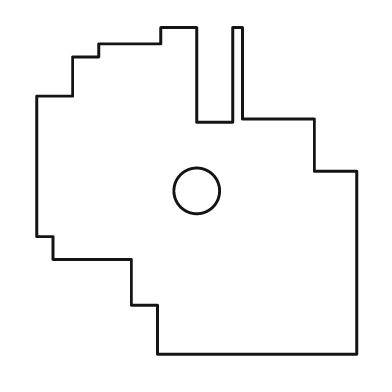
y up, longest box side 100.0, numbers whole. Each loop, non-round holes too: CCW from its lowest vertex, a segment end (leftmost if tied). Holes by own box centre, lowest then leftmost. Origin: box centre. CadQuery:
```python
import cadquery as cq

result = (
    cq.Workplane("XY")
    .moveTo(-12.0, -50.0)
    .lineTo(49.0, -50.0)
    .lineTo(49.0, 6.0)
    .lineTo(36.0, 6.0)
    .lineTo(36.0, 22.0)
    .lineTo(14.0, 22.0)
    .lineTo(14.0, 50.0)
    .lineTo(11.0, 50.0)
    .lineTo(11.0, 21.0)
    .lineTo(0.0, 21.0)
    .lineTo(0.0, 50.0)
    .lineTo(-11.0, 50.0)
    .lineTo(-11.0, 45.0)
    .lineTo(-30.0, 45.0)
    .lineTo(-30.0, 41.0)
    .lineTo(-38.0, 41.0)
    .lineTo(-38.0, 29.0)
    .lineTo(-49.0, 29.0)
    .lineTo(-49.0, -14.0)
    .lineTo(-44.0, -14.0)
    .lineTo(-44.0, -21.0)
    .lineTo(-20.0, -21.0)
    .lineTo(-20.0, -35.0)
    .lineTo(-12.0, -35.0)
    .close()
    .moveTo(0.0, 0.0)
    .circle(7.0)
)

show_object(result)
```